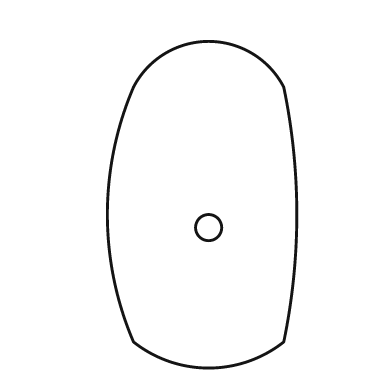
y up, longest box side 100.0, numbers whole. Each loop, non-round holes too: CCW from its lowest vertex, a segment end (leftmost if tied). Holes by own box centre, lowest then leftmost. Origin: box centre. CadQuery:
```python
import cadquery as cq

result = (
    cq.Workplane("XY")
    .moveTo(-21.0, -42.0)
    .threePointArc((2.0, -50.0), (25.0, -42.0))
    .threePointArc((29.0, -3.0), (25.0, 36.0))
    .threePointArc((2.0, 50.0), (-21.0, 36.0))
    .threePointArc((-29.0, -3.0), (-21.0, -42.0))
    .close()
    .moveTo(2.0, -7.0)
    .circle(4.0)
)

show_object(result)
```